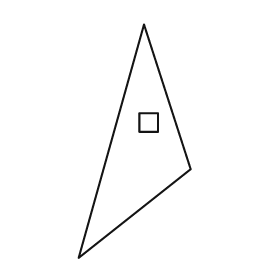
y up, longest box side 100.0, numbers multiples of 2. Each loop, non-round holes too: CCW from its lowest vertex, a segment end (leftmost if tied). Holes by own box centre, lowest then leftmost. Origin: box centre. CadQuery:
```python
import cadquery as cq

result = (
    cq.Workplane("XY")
    .moveTo(-24.0, -50.0)
    .lineTo(24.0, -12.0)
    .lineTo(4.0, 50.0)
    .close()
    .moveTo(2.0, 4.0)
    .lineTo(10.0, 4.0)
    .lineTo(10.0, 12.0)
    .lineTo(2.0, 12.0)
    .close()
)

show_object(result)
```